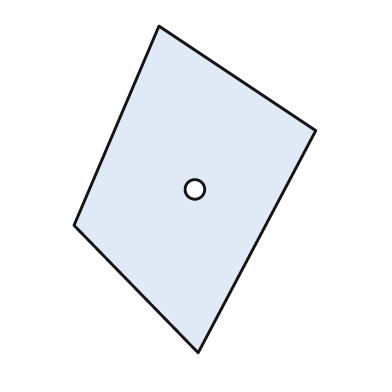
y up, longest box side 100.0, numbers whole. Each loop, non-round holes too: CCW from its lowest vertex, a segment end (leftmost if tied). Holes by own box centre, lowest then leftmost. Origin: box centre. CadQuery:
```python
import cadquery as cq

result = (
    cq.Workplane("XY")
    .moveTo(1.0, -50.0)
    .lineTo(37.0, 18.0)
    .lineTo(-11.0, 50.0)
    .lineTo(-37.0, -11.0)
    .close()
    .moveTo(0.0, 0.0)
    .circle(3.0)
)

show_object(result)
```